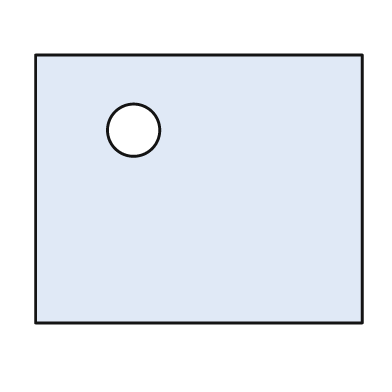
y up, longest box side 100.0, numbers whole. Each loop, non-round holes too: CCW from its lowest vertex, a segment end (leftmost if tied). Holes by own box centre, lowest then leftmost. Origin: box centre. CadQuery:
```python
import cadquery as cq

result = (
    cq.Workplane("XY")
    .moveTo(-50.0, -41.0)
    .lineTo(50.0, -41.0)
    .lineTo(50.0, 41.0)
    .lineTo(-50.0, 41.0)
    .close()
    .moveTo(-20.0, 18.0)
    .circle(8.0)
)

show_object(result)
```